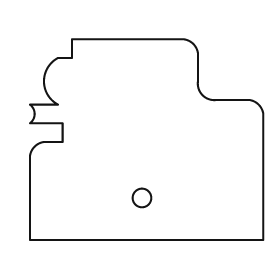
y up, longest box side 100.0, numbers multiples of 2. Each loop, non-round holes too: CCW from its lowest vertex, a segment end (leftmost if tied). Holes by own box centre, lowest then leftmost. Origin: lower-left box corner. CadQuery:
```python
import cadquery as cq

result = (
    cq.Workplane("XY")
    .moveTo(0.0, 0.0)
    .lineTo(100.0, 0.0)
    .lineTo(100.0, 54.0)
    .threePointArc((98.0, 58.0), (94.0, 60.0))
    .lineTo(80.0, 60.0)
    .threePointArc((74.0, 62.0), (72.0, 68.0))
    .lineTo(72.0, 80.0)
    .threePointArc((70.0, 84.0), (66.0, 86.0))
    .lineTo(18.0, 86.0)
    .lineTo(18.0, 78.0)
    .lineTo(12.0, 78.0)
    .threePointArc((6.0, 68.0), (12.0, 58.0))
    .lineTo(0.0, 58.0)
    .threePointArc((2.0, 54.0), (0.0, 50.0))
    .lineTo(14.0, 50.0)
    .lineTo(14.0, 42.0)
    .lineTo(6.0, 42.0)
    .threePointArc((2.0, 40.0), (0.0, 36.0))
    .close()
    .moveTo(48.0, 18.0)
    .circle(4.0)
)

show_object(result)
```